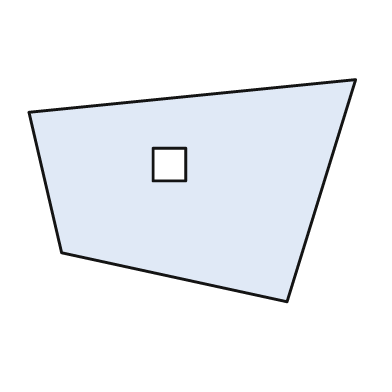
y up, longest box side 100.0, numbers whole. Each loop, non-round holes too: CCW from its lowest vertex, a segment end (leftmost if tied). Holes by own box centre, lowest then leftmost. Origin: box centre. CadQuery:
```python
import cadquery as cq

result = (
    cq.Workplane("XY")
    .moveTo(29.0, -34.0)
    .lineTo(50.0, 34.0)
    .lineTo(-50.0, 24.0)
    .lineTo(-40.0, -19.0)
    .close()
    .moveTo(-12.0, 3.0)
    .lineTo(-2.0, 3.0)
    .lineTo(-2.0, 13.0)
    .lineTo(-12.0, 13.0)
    .close()
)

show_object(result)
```